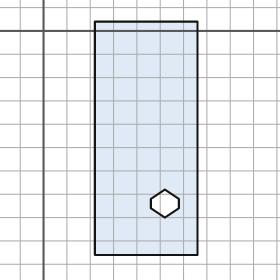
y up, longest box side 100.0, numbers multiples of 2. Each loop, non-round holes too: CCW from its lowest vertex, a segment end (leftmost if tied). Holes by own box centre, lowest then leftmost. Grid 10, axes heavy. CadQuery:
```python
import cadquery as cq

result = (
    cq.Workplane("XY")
    .moveTo(22.0, -96.0)
    .lineTo(66.0, -96.0)
    .lineTo(66.0, 4.0)
    .lineTo(22.0, 4.0)
    .close()
    .moveTo(52.0, -80.0)
    .lineTo(58.0, -76.0)
    .lineTo(58.0, -72.0)
    .lineTo(52.0, -68.0)
    .lineTo(46.0, -72.0)
    .lineTo(46.0, -76.0)
    .close()
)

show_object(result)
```